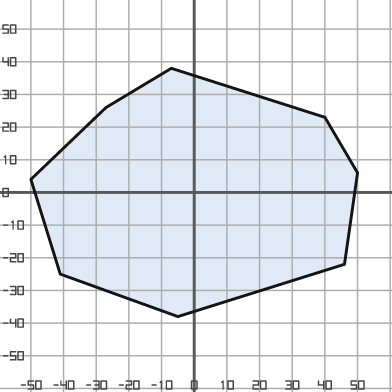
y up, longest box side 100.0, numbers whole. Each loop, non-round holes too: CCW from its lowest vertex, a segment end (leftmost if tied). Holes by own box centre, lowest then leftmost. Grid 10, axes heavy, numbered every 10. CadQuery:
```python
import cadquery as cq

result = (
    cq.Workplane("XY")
    .moveTo(-5.0, -38.0)
    .lineTo(46.0, -22.0)
    .lineTo(50.0, 6.0)
    .lineTo(40.0, 23.0)
    .lineTo(-7.0, 38.0)
    .lineTo(-27.0, 26.0)
    .lineTo(-50.0, 4.0)
    .lineTo(-41.0, -25.0)
    .close()
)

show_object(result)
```